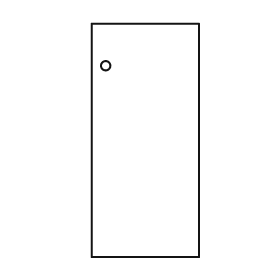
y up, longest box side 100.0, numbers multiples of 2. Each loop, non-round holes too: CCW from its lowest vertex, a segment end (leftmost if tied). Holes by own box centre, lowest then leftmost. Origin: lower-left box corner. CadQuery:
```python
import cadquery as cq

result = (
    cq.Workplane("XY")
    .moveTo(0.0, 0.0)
    .lineTo(46.0, 0.0)
    .lineTo(46.0, 100.0)
    .lineTo(0.0, 100.0)
    .close()
    .moveTo(6.0, 82.0)
    .circle(2.0)
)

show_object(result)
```